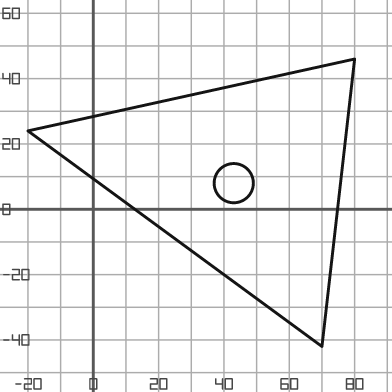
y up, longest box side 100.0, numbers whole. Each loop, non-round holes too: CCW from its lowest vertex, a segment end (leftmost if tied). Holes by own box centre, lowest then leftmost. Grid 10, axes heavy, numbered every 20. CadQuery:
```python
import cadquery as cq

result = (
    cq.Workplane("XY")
    .moveTo(70.0, -42.0)
    .lineTo(80.0, 46.0)
    .lineTo(-20.0, 24.0)
    .close()
    .moveTo(43.0, 8.0)
    .circle(6.0)
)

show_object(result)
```